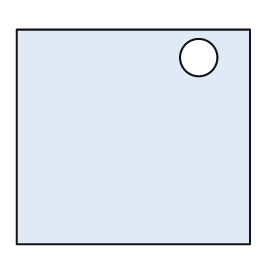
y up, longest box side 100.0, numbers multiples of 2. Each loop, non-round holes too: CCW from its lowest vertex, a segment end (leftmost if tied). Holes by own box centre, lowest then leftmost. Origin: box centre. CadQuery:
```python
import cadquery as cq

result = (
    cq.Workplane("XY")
    .moveTo(-50.0, -46.0)
    .lineTo(50.0, -46.0)
    .lineTo(50.0, 46.0)
    .lineTo(-50.0, 46.0)
    .close()
    .moveTo(28.0, 34.0)
    .circle(8.0)
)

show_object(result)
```